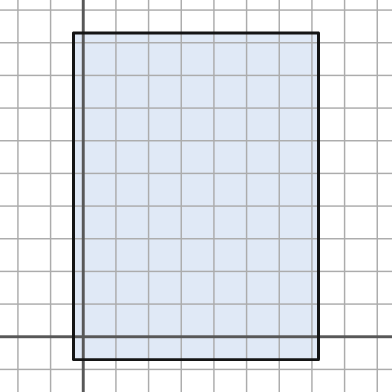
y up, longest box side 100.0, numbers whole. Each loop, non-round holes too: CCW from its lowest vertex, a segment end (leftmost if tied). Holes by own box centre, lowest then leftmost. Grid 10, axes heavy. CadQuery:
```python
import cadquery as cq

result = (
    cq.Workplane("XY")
    .moveTo(-3.0, -7.0)
    .lineTo(72.0, -7.0)
    .lineTo(72.0, 93.0)
    .lineTo(-3.0, 93.0)
    .close()
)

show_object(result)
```